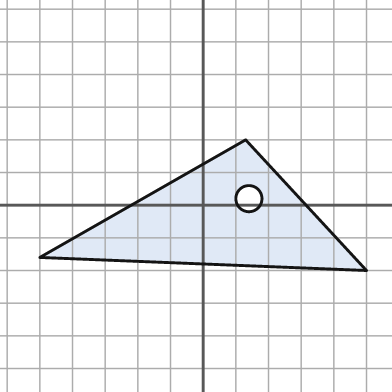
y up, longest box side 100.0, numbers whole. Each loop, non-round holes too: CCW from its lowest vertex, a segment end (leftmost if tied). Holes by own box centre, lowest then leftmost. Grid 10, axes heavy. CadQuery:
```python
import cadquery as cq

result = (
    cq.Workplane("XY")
    .moveTo(50.0, -20.0)
    .lineTo(13.0, 20.0)
    .lineTo(-50.0, -16.0)
    .close()
    .moveTo(14.0, 2.0)
    .circle(4.0)
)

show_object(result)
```